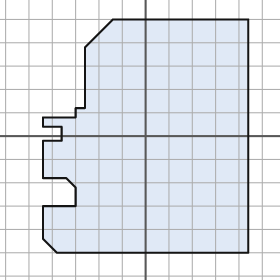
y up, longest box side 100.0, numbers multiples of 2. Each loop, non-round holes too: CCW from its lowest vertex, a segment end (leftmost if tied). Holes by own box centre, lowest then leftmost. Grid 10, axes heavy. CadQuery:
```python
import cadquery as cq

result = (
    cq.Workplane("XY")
    .moveTo(-38.0, -50.0)
    .lineTo(44.0, -50.0)
    .lineTo(44.0, 50.0)
    .lineTo(-14.0, 50.0)
    .lineTo(-26.0, 38.0)
    .lineTo(-26.0, 12.0)
    .lineTo(-30.0, 12.0)
    .lineTo(-30.0, 8.0)
    .lineTo(-44.0, 8.0)
    .lineTo(-44.0, 4.0)
    .lineTo(-36.0, 4.0)
    .lineTo(-36.0, -2.0)
    .lineTo(-44.0, -2.0)
    .lineTo(-44.0, -18.0)
    .lineTo(-34.0, -18.0)
    .lineTo(-30.0, -22.0)
    .lineTo(-30.0, -30.0)
    .lineTo(-44.0, -30.0)
    .lineTo(-44.0, -44.0)
    .close()
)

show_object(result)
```